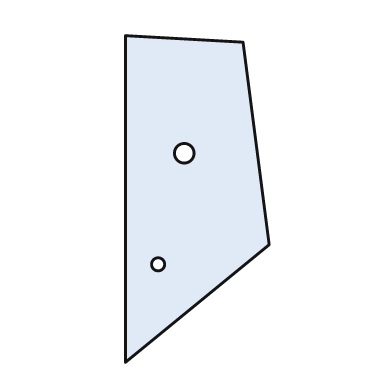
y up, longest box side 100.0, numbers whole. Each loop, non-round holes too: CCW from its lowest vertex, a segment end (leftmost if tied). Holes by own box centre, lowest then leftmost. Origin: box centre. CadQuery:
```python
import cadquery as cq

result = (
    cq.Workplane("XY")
    .moveTo(-22.0, -50.0)
    .lineTo(22.0, -14.0)
    .lineTo(14.0, 48.0)
    .lineTo(-22.0, 50.0)
    .close()
    .moveTo(-12.0, -20.0)
    .circle(2.0)
    .moveTo(-4.0, 14.0)
    .circle(3.0)
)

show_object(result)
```